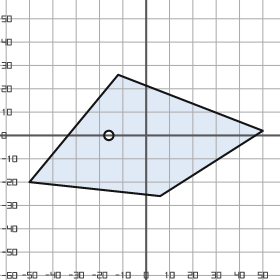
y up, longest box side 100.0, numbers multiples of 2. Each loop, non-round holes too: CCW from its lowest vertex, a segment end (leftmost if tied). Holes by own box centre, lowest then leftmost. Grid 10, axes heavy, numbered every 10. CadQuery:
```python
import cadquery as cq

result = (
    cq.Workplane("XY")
    .moveTo(6.0, -26.0)
    .lineTo(50.0, 2.0)
    .lineTo(-12.0, 26.0)
    .lineTo(-50.0, -20.0)
    .close()
    .moveTo(-16.0, 0.0)
    .circle(2.0)
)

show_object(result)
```